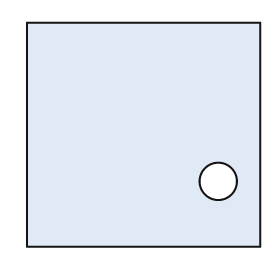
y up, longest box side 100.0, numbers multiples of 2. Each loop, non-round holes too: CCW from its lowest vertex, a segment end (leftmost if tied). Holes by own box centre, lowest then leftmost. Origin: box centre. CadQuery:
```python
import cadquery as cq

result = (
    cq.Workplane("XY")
    .moveTo(-50.0, -48.0)
    .lineTo(50.0, -48.0)
    .lineTo(50.0, 48.0)
    .lineTo(-50.0, 48.0)
    .close()
    .moveTo(32.0, -20.0)
    .circle(8.0)
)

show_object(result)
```